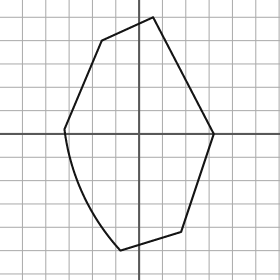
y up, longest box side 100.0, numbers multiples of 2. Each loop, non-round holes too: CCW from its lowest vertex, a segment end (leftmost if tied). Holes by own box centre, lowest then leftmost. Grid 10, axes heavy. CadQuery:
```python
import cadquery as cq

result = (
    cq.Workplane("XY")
    .moveTo(-8.0, -50.0)
    .lineTo(18.0, -42.0)
    .lineTo(32.0, 0.0)
    .lineTo(6.0, 50.0)
    .lineTo(-16.0, 40.0)
    .lineTo(-32.0, 2.0)
    .threePointArc((-24.0, -26.0), (-8.0, -50.0))
    .close()
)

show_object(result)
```